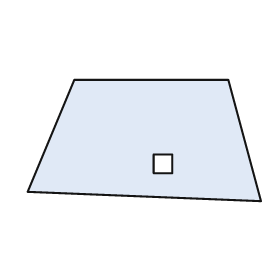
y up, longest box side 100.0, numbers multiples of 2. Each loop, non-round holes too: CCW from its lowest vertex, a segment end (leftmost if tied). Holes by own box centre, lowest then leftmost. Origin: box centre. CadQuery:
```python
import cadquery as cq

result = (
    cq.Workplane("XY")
    .moveTo(50.0, -26.0)
    .lineTo(36.0, 26.0)
    .lineTo(-30.0, 26.0)
    .lineTo(-50.0, -22.0)
    .close()
    .moveTo(4.0, -14.0)
    .lineTo(12.0, -14.0)
    .lineTo(12.0, -6.0)
    .lineTo(4.0, -6.0)
    .close()
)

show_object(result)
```